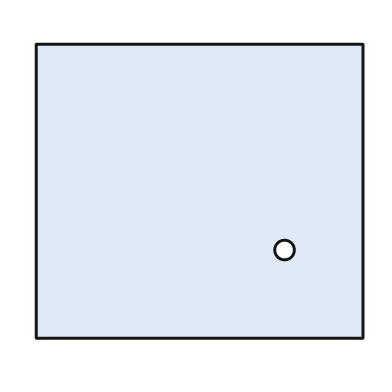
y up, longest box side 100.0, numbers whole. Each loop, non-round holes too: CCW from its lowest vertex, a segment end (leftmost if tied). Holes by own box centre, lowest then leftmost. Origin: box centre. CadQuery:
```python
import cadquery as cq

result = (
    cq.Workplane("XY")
    .moveTo(-50.0, -45.0)
    .lineTo(50.0, -45.0)
    .lineTo(50.0, 45.0)
    .lineTo(-50.0, 45.0)
    .close()
    .moveTo(26.0, -18.0)
    .circle(3.0)
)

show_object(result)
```